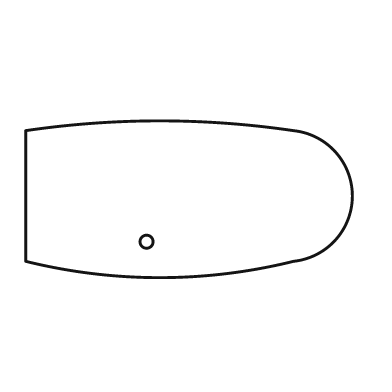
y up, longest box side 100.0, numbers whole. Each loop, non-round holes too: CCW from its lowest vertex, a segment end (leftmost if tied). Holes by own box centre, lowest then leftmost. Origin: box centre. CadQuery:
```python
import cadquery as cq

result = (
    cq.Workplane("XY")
    .moveTo(-50.0, -19.0)
    .threePointArc((-9.0, -24.0), (32.0, -19.0))
    .threePointArc((50.0, 1.0), (32.0, 21.0))
    .threePointArc((-9.0, 24.0), (-50.0, 21.0))
    .close()
    .moveTo(-13.0, -13.0)
    .circle(2.0)
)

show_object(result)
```